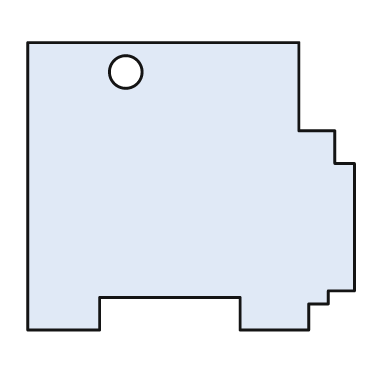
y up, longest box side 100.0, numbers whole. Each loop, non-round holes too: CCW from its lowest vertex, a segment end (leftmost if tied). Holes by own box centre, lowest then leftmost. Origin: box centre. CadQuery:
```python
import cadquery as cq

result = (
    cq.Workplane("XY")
    .moveTo(-50.0, -44.0)
    .lineTo(-28.0, -44.0)
    .lineTo(-28.0, -34.0)
    .lineTo(15.0, -34.0)
    .lineTo(15.0, -44.0)
    .lineTo(36.0, -44.0)
    .lineTo(36.0, -36.0)
    .lineTo(42.0, -36.0)
    .lineTo(42.0, -32.0)
    .lineTo(50.0, -32.0)
    .lineTo(50.0, 7.0)
    .lineTo(44.0, 7.0)
    .lineTo(44.0, 17.0)
    .lineTo(33.0, 17.0)
    .lineTo(33.0, 44.0)
    .lineTo(-50.0, 44.0)
    .close()
    .moveTo(-20.0, 35.0)
    .circle(5.0)
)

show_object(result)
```